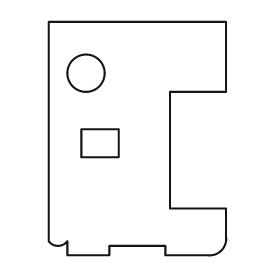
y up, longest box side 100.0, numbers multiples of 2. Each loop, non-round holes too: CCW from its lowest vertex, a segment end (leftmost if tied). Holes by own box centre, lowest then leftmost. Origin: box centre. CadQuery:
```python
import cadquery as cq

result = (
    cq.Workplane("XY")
    .moveTo(-30.0, -50.0)
    .lineTo(-12.0, -50.0)
    .lineTo(-12.0, -46.0)
    .lineTo(12.0, -46.0)
    .lineTo(12.0, -50.0)
    .lineTo(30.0, -50.0)
    .threePointArc((36.0, -48.0), (38.0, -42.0))
    .lineTo(38.0, -30.0)
    .lineTo(14.0, -30.0)
    .lineTo(14.0, 20.0)
    .lineTo(38.0, 20.0)
    .lineTo(38.0, 50.0)
    .lineTo(-38.0, 50.0)
    .lineTo(-38.0, -44.0)
    .threePointArc((-34.0, -46.0), (-30.0, -44.0))
    .close()
    .moveTo(-24.0, -8.0)
    .lineTo(-8.0, -8.0)
    .lineTo(-8.0, 4.0)
    .lineTo(-24.0, 4.0)
    .close()
    .moveTo(-22.0, 28.0)
    .circle(8.0)
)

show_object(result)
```